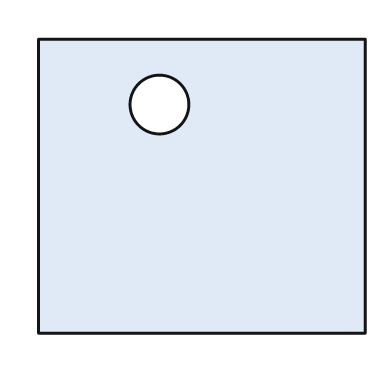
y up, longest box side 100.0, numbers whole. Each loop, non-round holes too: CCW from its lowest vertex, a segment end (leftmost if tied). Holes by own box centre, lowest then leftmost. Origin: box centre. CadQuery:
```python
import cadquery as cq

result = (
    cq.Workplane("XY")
    .moveTo(-50.0, -45.0)
    .lineTo(50.0, -45.0)
    .lineTo(50.0, 45.0)
    .lineTo(-50.0, 45.0)
    .close()
    .moveTo(-13.0, 25.0)
    .circle(9.0)
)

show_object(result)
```